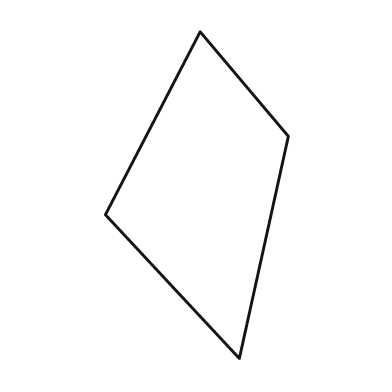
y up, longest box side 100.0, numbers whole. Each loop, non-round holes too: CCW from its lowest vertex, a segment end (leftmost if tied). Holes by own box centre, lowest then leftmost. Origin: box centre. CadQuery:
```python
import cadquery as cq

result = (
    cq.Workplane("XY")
    .moveTo(13.0, -50.0)
    .lineTo(28.0, 18.0)
    .lineTo(1.0, 50.0)
    .lineTo(-28.0, -6.0)
    .close()
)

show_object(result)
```